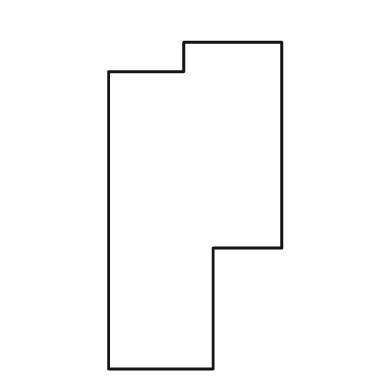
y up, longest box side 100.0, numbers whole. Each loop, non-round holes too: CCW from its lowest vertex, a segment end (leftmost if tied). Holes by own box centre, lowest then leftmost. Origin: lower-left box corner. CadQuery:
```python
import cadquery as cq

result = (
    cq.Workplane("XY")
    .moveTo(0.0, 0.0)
    .lineTo(32.0, 0.0)
    .lineTo(32.0, 37.0)
    .lineTo(53.0, 37.0)
    .lineTo(53.0, 100.0)
    .lineTo(23.0, 100.0)
    .lineTo(23.0, 91.0)
    .lineTo(0.0, 91.0)
    .close()
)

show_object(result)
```